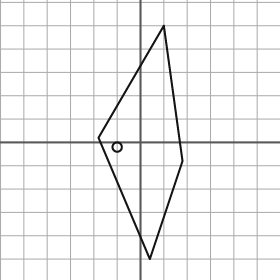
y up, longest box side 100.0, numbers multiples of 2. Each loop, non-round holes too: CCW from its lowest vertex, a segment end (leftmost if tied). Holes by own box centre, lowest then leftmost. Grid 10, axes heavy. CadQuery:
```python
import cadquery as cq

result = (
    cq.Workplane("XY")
    .moveTo(4.0, -50.0)
    .lineTo(18.0, -8.0)
    .lineTo(10.0, 50.0)
    .lineTo(-18.0, 2.0)
    .close()
    .moveTo(-10.0, -2.0)
    .circle(2.0)
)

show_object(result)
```